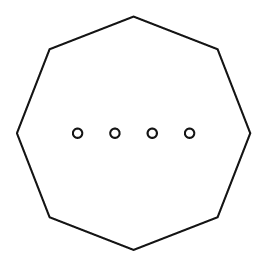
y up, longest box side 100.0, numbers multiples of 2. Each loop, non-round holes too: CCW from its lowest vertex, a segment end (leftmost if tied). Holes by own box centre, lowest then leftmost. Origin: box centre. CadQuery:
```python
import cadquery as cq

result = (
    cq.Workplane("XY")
    .moveTo(0.0, -50.0)
    .lineTo(36.0, -36.0)
    .lineTo(50.0, 0.0)
    .lineTo(36.0, 36.0)
    .lineTo(0.0, 50.0)
    .lineTo(-36.0, 36.0)
    .lineTo(-50.0, 0.0)
    .lineTo(-36.0, -36.0)
    .close()
    .moveTo(-24.0, 0.0)
    .circle(2.0)
    .moveTo(-8.0, 0.0)
    .circle(2.0)
    .moveTo(8.0, 0.0)
    .circle(2.0)
    .moveTo(24.0, 0.0)
    .circle(2.0)
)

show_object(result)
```